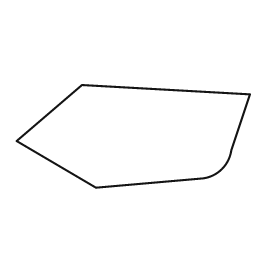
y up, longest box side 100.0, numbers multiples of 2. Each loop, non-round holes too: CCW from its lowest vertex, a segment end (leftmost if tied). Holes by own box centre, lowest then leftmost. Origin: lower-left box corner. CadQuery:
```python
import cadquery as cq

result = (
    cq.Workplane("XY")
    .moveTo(34.0, 0.0)
    .lineTo(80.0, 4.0)
    .threePointArc((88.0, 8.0), (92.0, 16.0))
    .lineTo(100.0, 40.0)
    .lineTo(28.0, 44.0)
    .lineTo(0.0, 20.0)
    .close()
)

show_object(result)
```